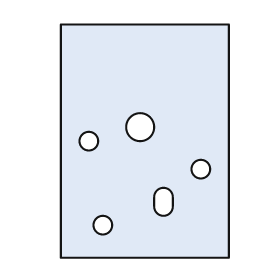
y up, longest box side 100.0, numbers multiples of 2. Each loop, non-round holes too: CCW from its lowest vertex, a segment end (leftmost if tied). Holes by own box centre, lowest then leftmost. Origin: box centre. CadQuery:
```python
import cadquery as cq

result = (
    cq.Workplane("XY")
    .moveTo(-36.0, -50.0)
    .lineTo(36.0, -50.0)
    .lineTo(36.0, 50.0)
    .lineTo(-36.0, 50.0)
    .close()
    .moveTo(-18.0, -36.0)
    .circle(4.0)
    .moveTo(4.0, -28.0)
    .threePointArc((8.0, -32.0), (12.0, -28.0))
    .lineTo(12.0, -24.0)
    .threePointArc((8.0, -20.0), (4.0, -24.0))
    .close()
    .moveTo(24.0, -12.0)
    .circle(4.0)
    .moveTo(-24.0, 0.0)
    .circle(4.0)
    .moveTo(-2.0, 6.0)
    .circle(6.0)
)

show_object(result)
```